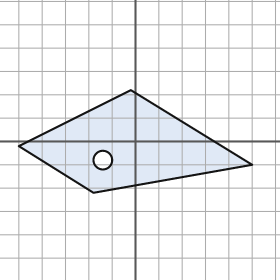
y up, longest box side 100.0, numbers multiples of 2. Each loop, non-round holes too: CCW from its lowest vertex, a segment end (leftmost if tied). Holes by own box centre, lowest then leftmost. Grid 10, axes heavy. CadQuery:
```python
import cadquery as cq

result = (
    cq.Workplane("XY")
    .moveTo(-18.0, -22.0)
    .lineTo(50.0, -10.0)
    .lineTo(-2.0, 22.0)
    .lineTo(-50.0, -2.0)
    .close()
    .moveTo(-14.0, -8.0)
    .circle(4.0)
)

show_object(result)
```